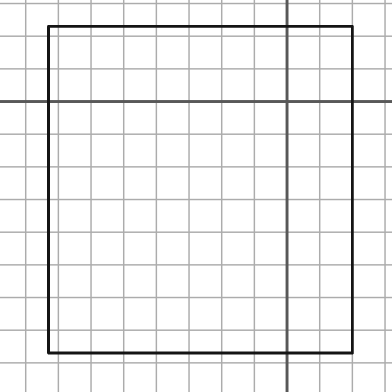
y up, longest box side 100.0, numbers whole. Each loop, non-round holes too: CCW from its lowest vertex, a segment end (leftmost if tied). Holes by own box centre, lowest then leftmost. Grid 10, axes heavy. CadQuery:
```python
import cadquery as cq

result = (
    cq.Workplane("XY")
    .moveTo(-73.0, -77.0)
    .lineTo(20.0, -77.0)
    .lineTo(20.0, 23.0)
    .lineTo(-73.0, 23.0)
    .close()
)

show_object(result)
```